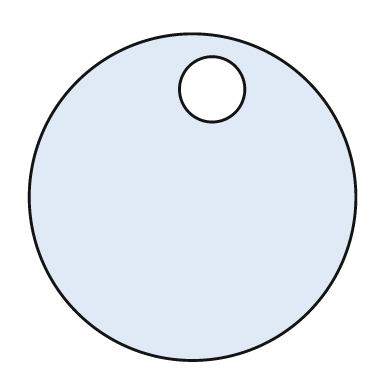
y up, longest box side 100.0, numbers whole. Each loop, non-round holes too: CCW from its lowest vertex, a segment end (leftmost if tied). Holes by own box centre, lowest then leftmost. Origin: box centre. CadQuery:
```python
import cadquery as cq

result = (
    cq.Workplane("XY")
    .moveTo(0.0, 0.0)
    .circle(50.0)
    .moveTo(6.0, 33.0)
    .circle(10.0)
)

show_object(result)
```